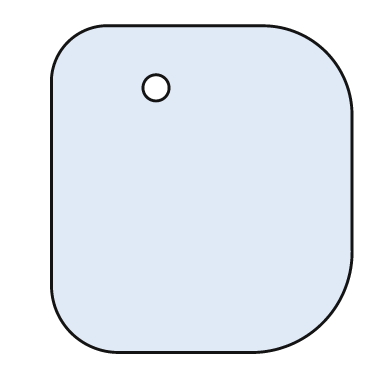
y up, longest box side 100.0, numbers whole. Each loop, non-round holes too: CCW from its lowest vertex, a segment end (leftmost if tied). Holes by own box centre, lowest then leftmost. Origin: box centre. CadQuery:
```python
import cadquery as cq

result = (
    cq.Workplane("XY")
    .moveTo(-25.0, -50.0)
    .lineTo(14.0, -50.0)
    .threePointArc((37.0, -41.0), (46.0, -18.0))
    .lineTo(46.0, 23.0)
    .threePointArc((38.0, 42.0), (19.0, 50.0))
    .lineTo(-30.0, 50.0)
    .threePointArc((-41.0, 45.0), (-46.0, 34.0))
    .lineTo(-46.0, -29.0)
    .threePointArc((-40.0, -44.0), (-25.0, -50.0))
    .close()
    .moveTo(-14.0, 31.0)
    .circle(4.0)
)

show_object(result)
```